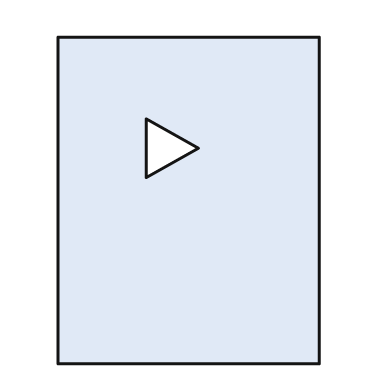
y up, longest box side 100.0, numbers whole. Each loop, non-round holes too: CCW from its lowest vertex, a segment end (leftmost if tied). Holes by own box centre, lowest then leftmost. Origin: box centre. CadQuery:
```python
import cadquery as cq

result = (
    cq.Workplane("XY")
    .moveTo(-40.0, -50.0)
    .lineTo(40.0, -50.0)
    .lineTo(40.0, 50.0)
    .lineTo(-40.0, 50.0)
    .close()
    .moveTo(-13.0, 7.0)
    .lineTo(3.0, 16.0)
    .lineTo(-13.0, 25.0)
    .close()
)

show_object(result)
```